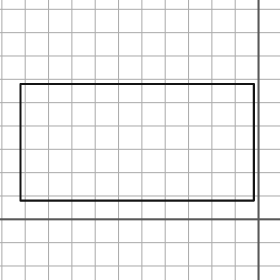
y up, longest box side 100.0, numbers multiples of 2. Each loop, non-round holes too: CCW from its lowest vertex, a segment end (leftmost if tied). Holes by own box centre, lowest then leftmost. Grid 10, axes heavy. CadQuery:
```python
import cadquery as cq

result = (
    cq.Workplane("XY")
    .moveTo(-102.0, 8.0)
    .lineTo(-2.0, 8.0)
    .lineTo(-2.0, 58.0)
    .lineTo(-102.0, 58.0)
    .close()
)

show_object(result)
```